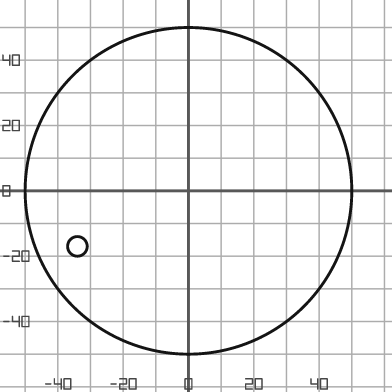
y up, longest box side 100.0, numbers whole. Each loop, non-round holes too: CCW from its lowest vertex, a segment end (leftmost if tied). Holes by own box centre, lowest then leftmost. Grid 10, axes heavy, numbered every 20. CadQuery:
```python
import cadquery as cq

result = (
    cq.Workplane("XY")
    .moveTo(0.0, 0.0)
    .circle(50.0)
    .moveTo(-34.0, -17.0)
    .circle(3.0)
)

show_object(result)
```